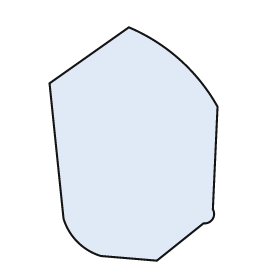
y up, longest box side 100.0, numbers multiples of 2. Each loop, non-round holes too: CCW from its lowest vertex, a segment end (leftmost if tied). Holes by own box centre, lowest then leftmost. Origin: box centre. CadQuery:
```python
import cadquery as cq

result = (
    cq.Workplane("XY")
    .moveTo(10.0, -50.0)
    .lineTo(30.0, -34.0)
    .threePointArc((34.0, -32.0), (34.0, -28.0))
    .lineTo(36.0, 16.0)
    .threePointArc((20.0, 36.0), (-2.0, 50.0))
    .lineTo(-36.0, 26.0)
    .lineTo(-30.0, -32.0)
    .threePointArc((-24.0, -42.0), (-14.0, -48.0))
    .close()
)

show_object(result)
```